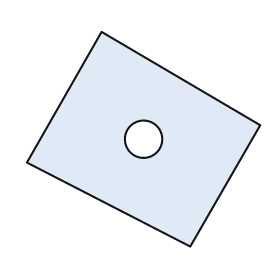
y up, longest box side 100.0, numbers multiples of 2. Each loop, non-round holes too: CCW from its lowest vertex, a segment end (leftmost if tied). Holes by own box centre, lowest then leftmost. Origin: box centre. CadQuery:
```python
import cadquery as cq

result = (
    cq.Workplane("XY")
    .moveTo(20.0, -46.0)
    .lineTo(50.0, 6.0)
    .lineTo(-18.0, 46.0)
    .lineTo(-50.0, -10.0)
    .close()
    .moveTo(0.0, 0.0)
    .circle(8.0)
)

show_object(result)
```